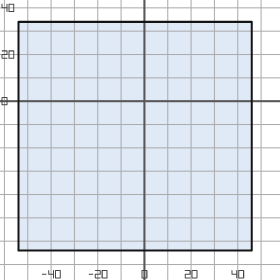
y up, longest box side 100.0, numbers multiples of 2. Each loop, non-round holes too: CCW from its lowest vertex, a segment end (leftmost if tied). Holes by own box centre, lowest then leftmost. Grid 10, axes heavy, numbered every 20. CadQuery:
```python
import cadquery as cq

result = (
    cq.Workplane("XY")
    .moveTo(-54.0, -64.0)
    .lineTo(46.0, -64.0)
    .lineTo(46.0, 34.0)
    .lineTo(-54.0, 34.0)
    .close()
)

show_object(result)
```